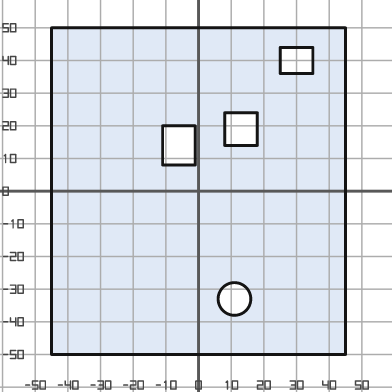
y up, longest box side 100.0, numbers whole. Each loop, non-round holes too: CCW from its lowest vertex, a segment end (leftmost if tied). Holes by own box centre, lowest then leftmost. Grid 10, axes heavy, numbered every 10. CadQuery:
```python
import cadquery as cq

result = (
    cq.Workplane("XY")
    .moveTo(-45.0, -50.0)
    .lineTo(45.0, -50.0)
    .lineTo(45.0, 50.0)
    .lineTo(-45.0, 50.0)
    .close()
    .moveTo(11.0, -33.0)
    .circle(5.0)
    .moveTo(-11.0, 8.0)
    .lineTo(-1.0, 8.0)
    .lineTo(-1.0, 20.0)
    .lineTo(-11.0, 20.0)
    .close()
    .moveTo(8.0, 14.0)
    .lineTo(18.0, 14.0)
    .lineTo(18.0, 24.0)
    .lineTo(8.0, 24.0)
    .close()
    .moveTo(25.0, 36.0)
    .lineTo(35.0, 36.0)
    .lineTo(35.0, 44.0)
    .lineTo(25.0, 44.0)
    .close()
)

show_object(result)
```